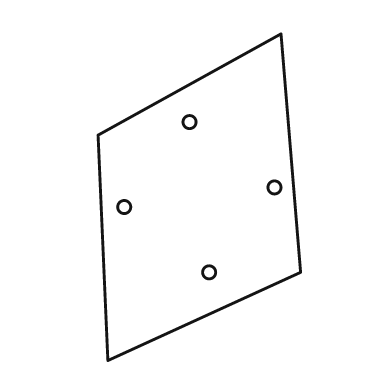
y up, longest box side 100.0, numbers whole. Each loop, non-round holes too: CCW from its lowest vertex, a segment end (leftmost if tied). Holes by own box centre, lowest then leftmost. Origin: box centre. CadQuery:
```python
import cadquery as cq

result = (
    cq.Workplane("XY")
    .moveTo(-28.0, -50.0)
    .lineTo(31.0, -23.0)
    .lineTo(25.0, 50.0)
    .lineTo(-31.0, 19.0)
    .close()
    .moveTo(3.0, -23.0)
    .circle(2.0)
    .moveTo(-23.0, -3.0)
    .circle(2.0)
    .moveTo(23.0, 3.0)
    .circle(2.0)
    .moveTo(-3.0, 23.0)
    .circle(2.0)
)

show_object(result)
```